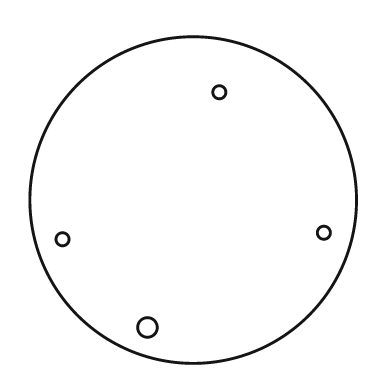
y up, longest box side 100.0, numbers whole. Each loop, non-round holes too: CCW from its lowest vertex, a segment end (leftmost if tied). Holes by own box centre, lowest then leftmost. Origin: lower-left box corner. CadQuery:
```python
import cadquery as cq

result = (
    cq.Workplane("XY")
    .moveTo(50.0, 50.0)
    .circle(50.0)
    .moveTo(36.0, 11.0)
    .circle(3.0)
    .moveTo(10.0, 38.0)
    .circle(2.0)
    .moveTo(90.0, 40.0)
    .circle(2.0)
    .moveTo(58.0, 83.0)
    .circle(2.0)
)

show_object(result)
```